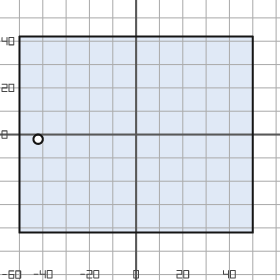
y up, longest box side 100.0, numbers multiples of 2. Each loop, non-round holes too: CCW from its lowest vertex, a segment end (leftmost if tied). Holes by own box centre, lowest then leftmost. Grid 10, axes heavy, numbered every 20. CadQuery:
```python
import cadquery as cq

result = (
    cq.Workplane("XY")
    .moveTo(-50.0, -42.0)
    .lineTo(50.0, -42.0)
    .lineTo(50.0, 42.0)
    .lineTo(-50.0, 42.0)
    .close()
    .moveTo(-42.0, -2.0)
    .circle(2.0)
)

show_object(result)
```